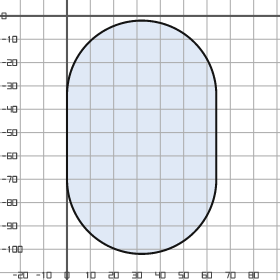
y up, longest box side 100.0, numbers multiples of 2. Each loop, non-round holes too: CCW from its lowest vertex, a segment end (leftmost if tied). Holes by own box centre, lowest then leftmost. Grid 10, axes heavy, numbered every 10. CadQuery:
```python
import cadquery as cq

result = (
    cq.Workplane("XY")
    .moveTo(0.0, -70.0)
    .threePointArc((32.0, -102.0), (64.0, -70.0))
    .lineTo(64.0, -34.0)
    .threePointArc((32.0, -2.0), (0.0, -34.0))
    .close()
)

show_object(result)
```